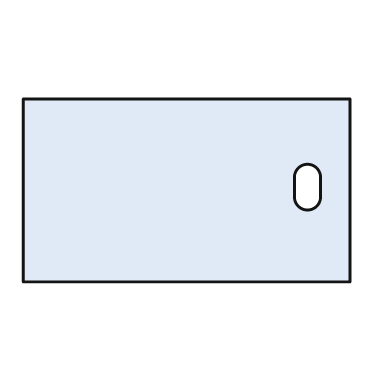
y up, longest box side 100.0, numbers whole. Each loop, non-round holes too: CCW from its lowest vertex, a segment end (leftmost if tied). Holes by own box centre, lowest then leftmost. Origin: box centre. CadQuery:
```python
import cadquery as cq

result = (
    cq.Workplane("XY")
    .moveTo(-50.0, -28.0)
    .lineTo(50.0, -28.0)
    .lineTo(50.0, 28.0)
    .lineTo(-50.0, 28.0)
    .close()
    .moveTo(33.0, -2.0)
    .threePointArc((37.0, -6.0), (41.0, -2.0))
    .lineTo(41.0, 4.0)
    .threePointArc((37.0, 8.0), (33.0, 4.0))
    .close()
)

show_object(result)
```